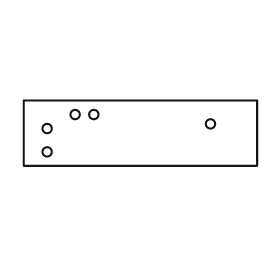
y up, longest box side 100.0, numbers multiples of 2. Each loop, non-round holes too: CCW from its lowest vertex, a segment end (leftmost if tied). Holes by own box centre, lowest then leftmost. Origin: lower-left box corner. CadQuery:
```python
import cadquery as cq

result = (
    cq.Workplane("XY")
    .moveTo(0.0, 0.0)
    .lineTo(100.0, 0.0)
    .lineTo(100.0, 28.0)
    .lineTo(0.0, 28.0)
    .close()
    .moveTo(10.0, 6.0)
    .circle(2.0)
    .moveTo(10.0, 16.0)
    .circle(2.0)
    .moveTo(80.0, 18.0)
    .circle(2.0)
    .moveTo(22.0, 22.0)
    .circle(2.0)
    .moveTo(30.0, 22.0)
    .circle(2.0)
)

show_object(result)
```